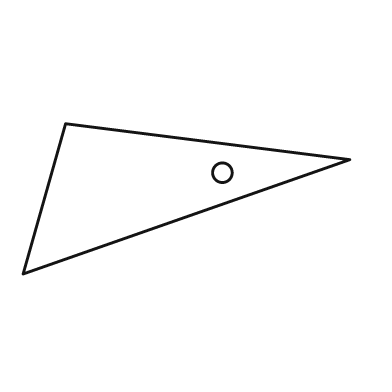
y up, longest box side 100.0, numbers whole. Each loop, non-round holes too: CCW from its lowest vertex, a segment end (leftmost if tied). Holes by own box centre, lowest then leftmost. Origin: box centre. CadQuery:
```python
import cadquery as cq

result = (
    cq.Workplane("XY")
    .moveTo(-50.0, -23.0)
    .lineTo(50.0, 12.0)
    .lineTo(-37.0, 23.0)
    .close()
    .moveTo(11.0, 8.0)
    .circle(3.0)
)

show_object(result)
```